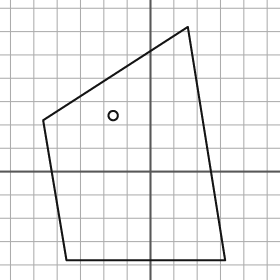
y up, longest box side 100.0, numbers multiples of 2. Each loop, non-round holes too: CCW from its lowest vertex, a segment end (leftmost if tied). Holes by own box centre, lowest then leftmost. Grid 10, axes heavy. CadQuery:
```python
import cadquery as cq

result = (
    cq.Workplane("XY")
    .moveTo(-36.0, -38.0)
    .lineTo(32.0, -38.0)
    .lineTo(16.0, 62.0)
    .lineTo(-46.0, 22.0)
    .close()
    .moveTo(-16.0, 24.0)
    .circle(2.0)
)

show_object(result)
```